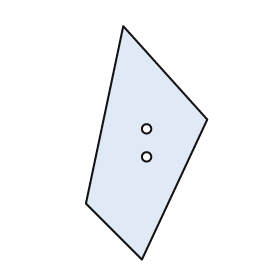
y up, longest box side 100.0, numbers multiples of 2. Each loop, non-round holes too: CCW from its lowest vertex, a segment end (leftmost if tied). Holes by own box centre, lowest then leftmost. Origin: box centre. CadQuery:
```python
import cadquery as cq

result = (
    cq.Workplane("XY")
    .moveTo(-2.0, -50.0)
    .lineTo(26.0, 10.0)
    .lineTo(-10.0, 50.0)
    .lineTo(-26.0, -26.0)
    .close()
    .moveTo(0.0, -6.0)
    .circle(2.0)
    .moveTo(0.0, 6.0)
    .circle(2.0)
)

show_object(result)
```